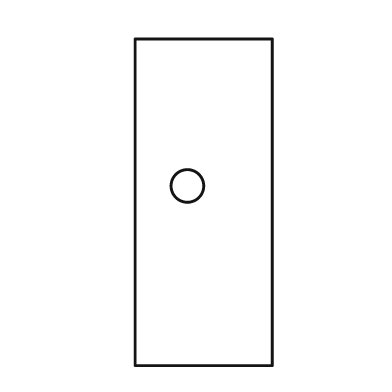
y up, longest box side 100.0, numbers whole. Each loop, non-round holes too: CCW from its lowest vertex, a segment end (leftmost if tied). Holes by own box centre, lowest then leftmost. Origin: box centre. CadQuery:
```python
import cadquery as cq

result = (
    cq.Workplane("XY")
    .moveTo(-21.0, -50.0)
    .lineTo(21.0, -50.0)
    .lineTo(21.0, 50.0)
    .lineTo(-21.0, 50.0)
    .close()
    .moveTo(-5.0, 5.0)
    .circle(5.0)
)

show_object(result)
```